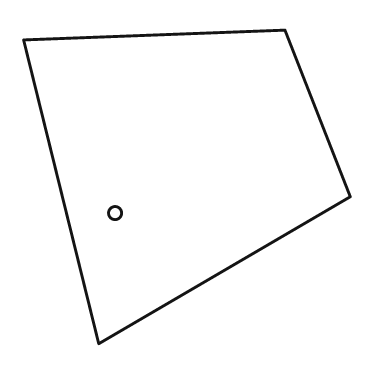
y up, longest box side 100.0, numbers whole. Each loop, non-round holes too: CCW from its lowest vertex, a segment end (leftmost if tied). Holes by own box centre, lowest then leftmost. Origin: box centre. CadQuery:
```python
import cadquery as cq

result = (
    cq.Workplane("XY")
    .moveTo(-27.0, -48.0)
    .lineTo(50.0, -3.0)
    .lineTo(30.0, 48.0)
    .lineTo(-50.0, 45.0)
    .close()
    .moveTo(-22.0, -8.0)
    .circle(2.0)
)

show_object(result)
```